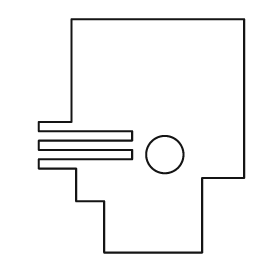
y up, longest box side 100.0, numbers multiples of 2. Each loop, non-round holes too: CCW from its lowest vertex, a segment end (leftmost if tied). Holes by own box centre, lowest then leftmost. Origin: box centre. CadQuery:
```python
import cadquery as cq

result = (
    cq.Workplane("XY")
    .moveTo(-16.0, -50.0)
    .lineTo(26.0, -50.0)
    .lineTo(26.0, -18.0)
    .lineTo(44.0, -18.0)
    .lineTo(44.0, 50.0)
    .lineTo(-30.0, 50.0)
    .lineTo(-30.0, 6.0)
    .lineTo(-44.0, 6.0)
    .lineTo(-44.0, 2.0)
    .lineTo(-4.0, 2.0)
    .lineTo(-4.0, -2.0)
    .lineTo(-44.0, -2.0)
    .lineTo(-44.0, -6.0)
    .lineTo(-4.0, -6.0)
    .lineTo(-4.0, -10.0)
    .lineTo(-44.0, -10.0)
    .lineTo(-44.0, -14.0)
    .lineTo(-28.0, -14.0)
    .lineTo(-28.0, -28.0)
    .lineTo(-16.0, -28.0)
    .close()
    .moveTo(10.0, -8.0)
    .circle(8.0)
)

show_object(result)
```